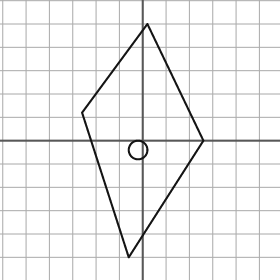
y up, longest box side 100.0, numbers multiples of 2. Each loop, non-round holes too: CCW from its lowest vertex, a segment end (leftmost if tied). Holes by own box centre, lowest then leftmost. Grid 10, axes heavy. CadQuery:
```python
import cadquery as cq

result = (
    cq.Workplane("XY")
    .moveTo(-6.0, -50.0)
    .lineTo(26.0, 0.0)
    .lineTo(2.0, 50.0)
    .lineTo(-26.0, 12.0)
    .close()
    .moveTo(-2.0, -4.0)
    .circle(4.0)
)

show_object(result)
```